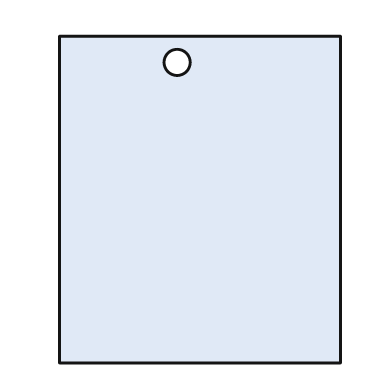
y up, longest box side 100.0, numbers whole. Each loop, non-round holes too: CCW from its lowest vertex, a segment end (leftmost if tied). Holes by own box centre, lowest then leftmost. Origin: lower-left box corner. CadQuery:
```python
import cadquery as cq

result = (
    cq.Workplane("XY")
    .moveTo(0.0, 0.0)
    .lineTo(86.0, 0.0)
    .lineTo(86.0, 100.0)
    .lineTo(0.0, 100.0)
    .close()
    .moveTo(36.0, 92.0)
    .circle(4.0)
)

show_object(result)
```